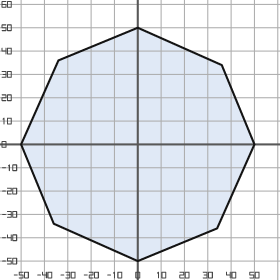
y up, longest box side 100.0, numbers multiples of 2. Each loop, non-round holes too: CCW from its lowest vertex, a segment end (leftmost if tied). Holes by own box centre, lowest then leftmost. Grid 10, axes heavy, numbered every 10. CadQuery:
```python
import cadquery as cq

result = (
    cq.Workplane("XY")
    .moveTo(0.0, -50.0)
    .lineTo(34.0, -36.0)
    .lineTo(50.0, 0.0)
    .lineTo(36.0, 34.0)
    .lineTo(0.0, 50.0)
    .lineTo(-34.0, 36.0)
    .lineTo(-50.0, 0.0)
    .lineTo(-36.0, -34.0)
    .close()
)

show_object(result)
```